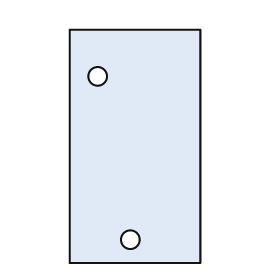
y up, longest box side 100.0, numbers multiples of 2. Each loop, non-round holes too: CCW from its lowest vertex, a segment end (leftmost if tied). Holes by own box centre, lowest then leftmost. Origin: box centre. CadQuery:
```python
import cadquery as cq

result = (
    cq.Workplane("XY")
    .moveTo(-28.0, -50.0)
    .lineTo(28.0, -50.0)
    .lineTo(28.0, 50.0)
    .lineTo(-28.0, 50.0)
    .close()
    .moveTo(-2.0, -40.0)
    .circle(4.0)
    .moveTo(-16.0, 30.0)
    .circle(4.0)
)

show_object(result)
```